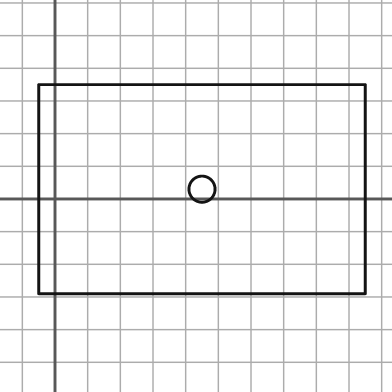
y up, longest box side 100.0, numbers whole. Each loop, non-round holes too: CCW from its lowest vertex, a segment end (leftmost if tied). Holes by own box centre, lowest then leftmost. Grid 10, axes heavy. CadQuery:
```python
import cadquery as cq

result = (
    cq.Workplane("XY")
    .moveTo(-5.0, -29.0)
    .lineTo(95.0, -29.0)
    .lineTo(95.0, 35.0)
    .lineTo(-5.0, 35.0)
    .close()
    .moveTo(45.0, 3.0)
    .circle(4.0)
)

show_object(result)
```